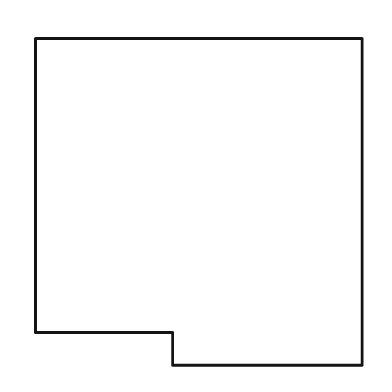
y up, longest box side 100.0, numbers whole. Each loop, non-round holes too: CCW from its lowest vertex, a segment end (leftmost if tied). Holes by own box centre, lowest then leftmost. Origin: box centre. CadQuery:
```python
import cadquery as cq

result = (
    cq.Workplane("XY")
    .moveTo(-8.0, -50.0)
    .lineTo(50.0, -50.0)
    .lineTo(50.0, 50.0)
    .lineTo(-50.0, 50.0)
    .lineTo(-50.0, -40.0)
    .lineTo(-8.0, -40.0)
    .close()
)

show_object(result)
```